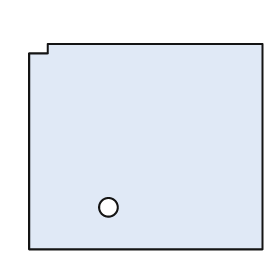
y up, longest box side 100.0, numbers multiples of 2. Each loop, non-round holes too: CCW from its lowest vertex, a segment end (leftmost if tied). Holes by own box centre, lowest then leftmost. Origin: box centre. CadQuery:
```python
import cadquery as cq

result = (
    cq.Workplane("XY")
    .moveTo(-50.0, -44.0)
    .lineTo(50.0, -44.0)
    .lineTo(50.0, 44.0)
    .lineTo(-42.0, 44.0)
    .lineTo(-42.0, 40.0)
    .lineTo(-50.0, 40.0)
    .close()
    .moveTo(-16.0, -26.0)
    .circle(4.0)
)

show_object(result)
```